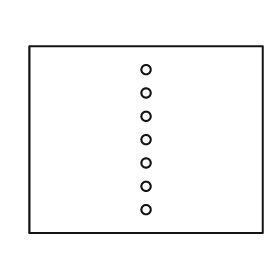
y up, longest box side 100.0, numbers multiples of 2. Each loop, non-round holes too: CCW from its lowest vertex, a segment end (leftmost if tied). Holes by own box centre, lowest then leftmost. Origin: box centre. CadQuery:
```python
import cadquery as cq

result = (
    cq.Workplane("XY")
    .moveTo(-50.0, -40.0)
    .lineTo(50.0, -40.0)
    .lineTo(50.0, 40.0)
    .lineTo(-50.0, 40.0)
    .close()
    .moveTo(0.0, -30.0)
    .circle(2.0)
    .moveTo(0.0, -20.0)
    .circle(2.0)
    .moveTo(0.0, -10.0)
    .circle(2.0)
    .moveTo(0.0, 0.0)
    .circle(2.0)
    .moveTo(0.0, 10.0)
    .circle(2.0)
    .moveTo(0.0, 20.0)
    .circle(2.0)
    .moveTo(0.0, 30.0)
    .circle(2.0)
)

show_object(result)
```